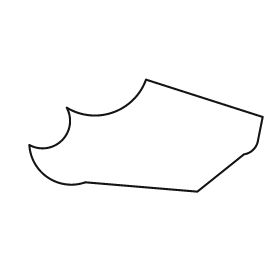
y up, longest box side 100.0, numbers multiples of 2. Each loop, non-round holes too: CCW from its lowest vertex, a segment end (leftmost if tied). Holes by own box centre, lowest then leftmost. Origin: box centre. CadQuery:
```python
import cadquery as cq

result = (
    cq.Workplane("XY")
    .moveTo(22.0, -24.0)
    .lineTo(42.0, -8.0)
    .threePointArc((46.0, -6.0), (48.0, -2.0))
    .lineTo(50.0, 8.0)
    .lineTo(0.0, 24.0)
    .threePointArc((-14.0, 10.0), (-34.0, 12.0))
    .threePointArc((-36.0, -2.0), (-50.0, -4.0))
    .threePointArc((-42.0, -18.0), (-26.0, -20.0))
    .close()
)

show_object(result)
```